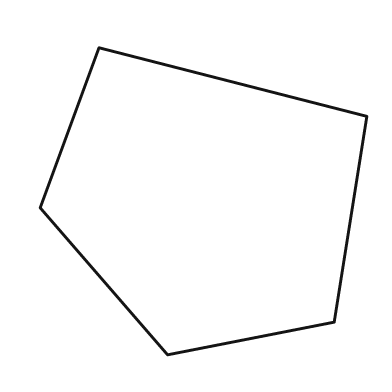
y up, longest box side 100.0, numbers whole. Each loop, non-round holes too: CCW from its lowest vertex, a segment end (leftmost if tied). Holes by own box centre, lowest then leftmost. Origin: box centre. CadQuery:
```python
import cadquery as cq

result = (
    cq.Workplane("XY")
    .moveTo(-11.0, -47.0)
    .lineTo(40.0, -37.0)
    .lineTo(50.0, 26.0)
    .lineTo(-32.0, 47.0)
    .lineTo(-50.0, -2.0)
    .close()
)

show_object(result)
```